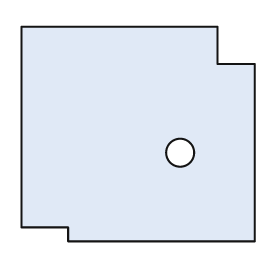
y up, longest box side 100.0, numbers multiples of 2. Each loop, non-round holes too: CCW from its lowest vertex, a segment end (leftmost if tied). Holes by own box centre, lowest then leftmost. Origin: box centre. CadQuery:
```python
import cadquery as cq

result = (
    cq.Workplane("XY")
    .moveTo(-30.0, -46.0)
    .lineTo(50.0, -46.0)
    .lineTo(50.0, 30.0)
    .lineTo(34.0, 30.0)
    .lineTo(34.0, 46.0)
    .lineTo(-50.0, 46.0)
    .lineTo(-50.0, -40.0)
    .lineTo(-30.0, -40.0)
    .close()
    .moveTo(18.0, -8.0)
    .circle(6.0)
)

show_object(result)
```